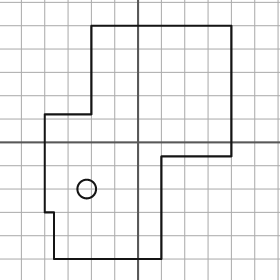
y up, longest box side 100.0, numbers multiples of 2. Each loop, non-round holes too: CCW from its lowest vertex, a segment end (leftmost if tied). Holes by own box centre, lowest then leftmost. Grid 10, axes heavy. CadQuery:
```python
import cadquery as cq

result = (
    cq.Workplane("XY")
    .moveTo(-36.0, -50.0)
    .lineTo(10.0, -50.0)
    .lineTo(10.0, -6.0)
    .lineTo(40.0, -6.0)
    .lineTo(40.0, 50.0)
    .lineTo(-20.0, 50.0)
    .lineTo(-20.0, 12.0)
    .lineTo(-40.0, 12.0)
    .lineTo(-40.0, -30.0)
    .lineTo(-36.0, -30.0)
    .close()
    .moveTo(-22.0, -20.0)
    .circle(4.0)
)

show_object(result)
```